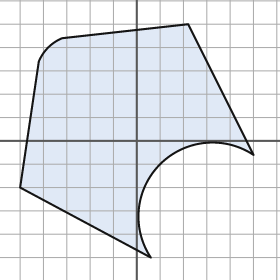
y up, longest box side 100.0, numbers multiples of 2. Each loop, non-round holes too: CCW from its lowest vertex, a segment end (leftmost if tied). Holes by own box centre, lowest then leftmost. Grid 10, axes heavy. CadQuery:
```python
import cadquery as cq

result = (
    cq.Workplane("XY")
    .moveTo(6.0, -50.0)
    .threePointArc((10.0, -10.0), (50.0, -6.0))
    .lineTo(22.0, 50.0)
    .lineTo(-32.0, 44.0)
    .threePointArc((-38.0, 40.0), (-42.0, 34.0))
    .lineTo(-50.0, -20.0)
    .close()
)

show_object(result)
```